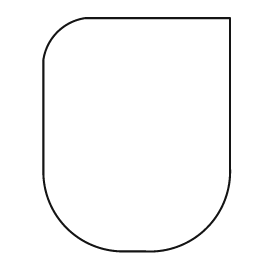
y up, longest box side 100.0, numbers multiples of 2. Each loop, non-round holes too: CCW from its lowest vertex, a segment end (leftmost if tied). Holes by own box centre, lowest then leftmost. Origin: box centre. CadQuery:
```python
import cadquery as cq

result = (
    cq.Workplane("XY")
    .moveTo(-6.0, -50.0)
    .lineTo(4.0, -50.0)
    .threePointArc((30.0, -40.0), (40.0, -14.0))
    .lineTo(40.0, 50.0)
    .lineTo(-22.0, 50.0)
    .threePointArc((-34.0, 44.0), (-40.0, 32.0))
    .lineTo(-40.0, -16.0)
    .threePointArc((-30.0, -40.0), (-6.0, -50.0))
    .close()
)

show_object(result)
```